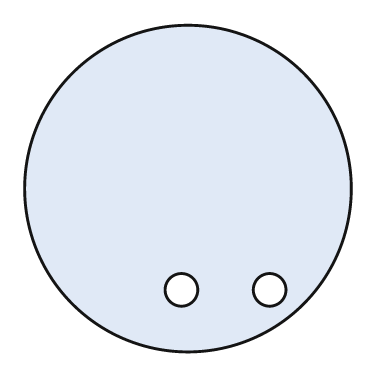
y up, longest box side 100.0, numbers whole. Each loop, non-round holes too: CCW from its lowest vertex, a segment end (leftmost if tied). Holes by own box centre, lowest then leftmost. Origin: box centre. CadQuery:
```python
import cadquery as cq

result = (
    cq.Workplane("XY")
    .moveTo(0.0, 0.0)
    .circle(50.0)
    .moveTo(-2.0, -31.0)
    .circle(5.0)
    .moveTo(25.0, -31.0)
    .circle(5.0)
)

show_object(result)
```